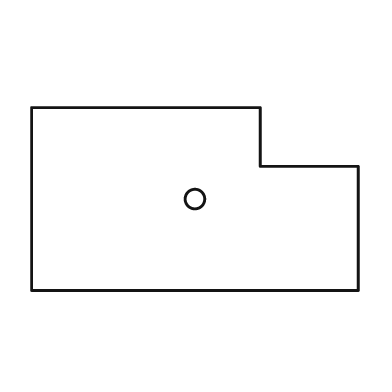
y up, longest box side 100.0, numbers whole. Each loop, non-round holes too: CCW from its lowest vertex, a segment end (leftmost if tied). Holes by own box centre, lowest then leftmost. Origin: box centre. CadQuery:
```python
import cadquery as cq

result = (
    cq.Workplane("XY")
    .moveTo(-50.0, -28.0)
    .lineTo(50.0, -28.0)
    .lineTo(50.0, 10.0)
    .lineTo(20.0, 10.0)
    .lineTo(20.0, 28.0)
    .lineTo(-50.0, 28.0)
    .close()
    .moveTo(0.0, 0.0)
    .circle(3.0)
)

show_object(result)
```